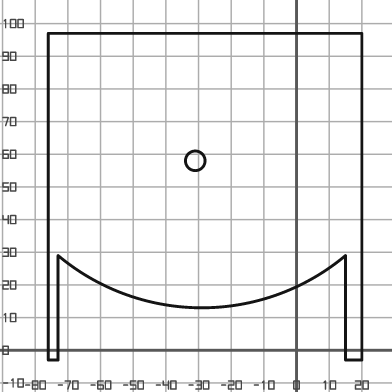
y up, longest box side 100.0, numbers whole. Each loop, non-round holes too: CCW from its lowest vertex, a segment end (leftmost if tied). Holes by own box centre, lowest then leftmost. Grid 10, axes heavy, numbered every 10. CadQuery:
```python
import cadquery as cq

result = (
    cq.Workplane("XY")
    .moveTo(-76.0, -3.0)
    .lineTo(-73.0, -3.0)
    .lineTo(-73.0, 29.0)
    .threePointArc((-29.0, 13.0), (15.0, 29.0))
    .lineTo(15.0, -3.0)
    .lineTo(20.0, -3.0)
    .lineTo(20.0, 97.0)
    .lineTo(-76.0, 97.0)
    .close()
    .moveTo(-31.0, 58.0)
    .circle(3.0)
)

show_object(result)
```